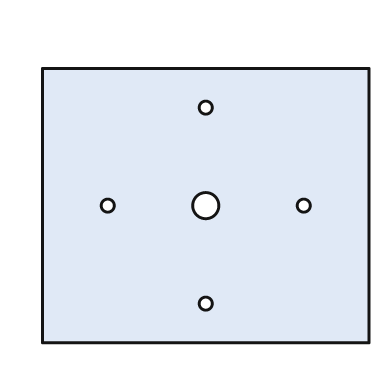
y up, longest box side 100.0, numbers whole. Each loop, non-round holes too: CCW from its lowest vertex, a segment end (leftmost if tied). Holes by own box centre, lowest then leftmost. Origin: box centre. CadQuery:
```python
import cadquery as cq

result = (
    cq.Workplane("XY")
    .moveTo(-50.0, -42.0)
    .lineTo(50.0, -42.0)
    .lineTo(50.0, 42.0)
    .lineTo(-50.0, 42.0)
    .close()
    .moveTo(0.0, -30.0)
    .circle(2.0)
    .moveTo(-30.0, 0.0)
    .circle(2.0)
    .moveTo(0.0, 0.0)
    .circle(4.0)
    .moveTo(30.0, 0.0)
    .circle(2.0)
    .moveTo(0.0, 30.0)
    .circle(2.0)
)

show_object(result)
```